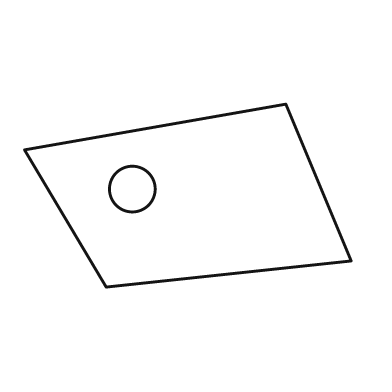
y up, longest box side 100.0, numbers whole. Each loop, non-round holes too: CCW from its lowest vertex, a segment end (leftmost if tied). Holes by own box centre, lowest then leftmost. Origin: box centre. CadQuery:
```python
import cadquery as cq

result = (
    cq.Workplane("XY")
    .moveTo(-25.0, -28.0)
    .lineTo(50.0, -20.0)
    .lineTo(30.0, 28.0)
    .lineTo(-50.0, 14.0)
    .close()
    .moveTo(-17.0, 2.0)
    .circle(7.0)
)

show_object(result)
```